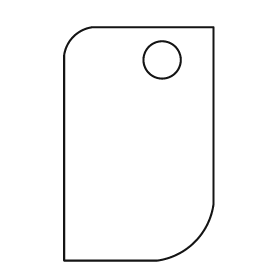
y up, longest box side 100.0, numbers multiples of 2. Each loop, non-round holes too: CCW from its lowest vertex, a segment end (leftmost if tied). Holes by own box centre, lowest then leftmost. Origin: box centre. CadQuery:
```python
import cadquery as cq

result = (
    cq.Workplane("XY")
    .moveTo(-32.0, -50.0)
    .lineTo(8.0, -50.0)
    .threePointArc((24.0, -42.0), (32.0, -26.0))
    .lineTo(32.0, 50.0)
    .lineTo(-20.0, 50.0)
    .threePointArc((-28.0, 46.0), (-32.0, 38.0))
    .close()
    .moveTo(10.0, 36.0)
    .circle(8.0)
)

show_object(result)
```